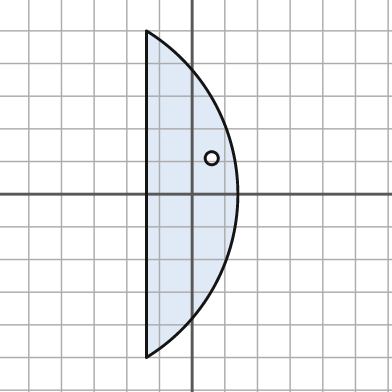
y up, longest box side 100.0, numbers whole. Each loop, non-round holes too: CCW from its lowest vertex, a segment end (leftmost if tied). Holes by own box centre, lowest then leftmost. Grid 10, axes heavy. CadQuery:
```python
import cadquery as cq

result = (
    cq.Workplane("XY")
    .moveTo(-14.0, -50.0)
    .threePointArc((14.0, 0.0), (-14.0, 50.0))
    .close()
    .moveTo(6.0, 11.0)
    .circle(2.0)
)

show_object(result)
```